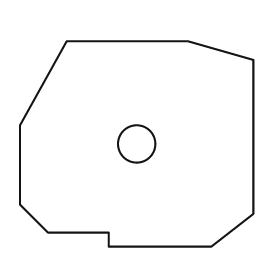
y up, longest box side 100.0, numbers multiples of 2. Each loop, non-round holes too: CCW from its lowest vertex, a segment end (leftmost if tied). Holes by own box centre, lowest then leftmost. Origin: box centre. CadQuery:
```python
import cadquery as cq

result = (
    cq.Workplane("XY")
    .moveTo(-12.0, -44.0)
    .lineTo(32.0, -44.0)
    .lineTo(50.0, -30.0)
    .lineTo(50.0, 36.0)
    .lineTo(22.0, 44.0)
    .lineTo(-30.0, 44.0)
    .lineTo(-50.0, 8.0)
    .lineTo(-50.0, -26.0)
    .lineTo(-38.0, -38.0)
    .lineTo(-12.0, -38.0)
    .close()
    .moveTo(0.0, 0.0)
    .circle(8.0)
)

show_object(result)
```